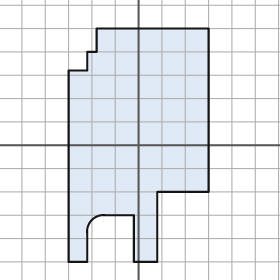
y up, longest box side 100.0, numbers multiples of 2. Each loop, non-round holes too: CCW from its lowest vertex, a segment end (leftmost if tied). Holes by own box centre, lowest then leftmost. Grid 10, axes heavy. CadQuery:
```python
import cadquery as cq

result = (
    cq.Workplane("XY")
    .moveTo(-30.0, -50.0)
    .lineTo(-22.0, -50.0)
    .lineTo(-22.0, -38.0)
    .threePointArc((-20.0, -32.0), (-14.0, -30.0))
    .lineTo(-2.0, -30.0)
    .lineTo(-2.0, -50.0)
    .lineTo(8.0, -50.0)
    .lineTo(8.0, -20.0)
    .lineTo(30.0, -20.0)
    .lineTo(30.0, 50.0)
    .lineTo(-18.0, 50.0)
    .lineTo(-18.0, 40.0)
    .lineTo(-22.0, 40.0)
    .lineTo(-22.0, 32.0)
    .lineTo(-30.0, 32.0)
    .close()
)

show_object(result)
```